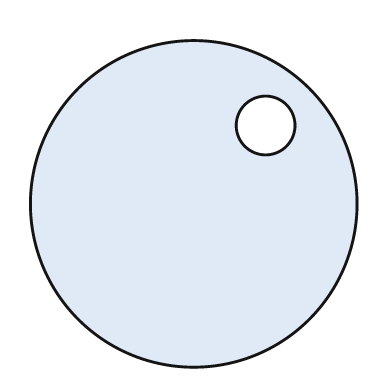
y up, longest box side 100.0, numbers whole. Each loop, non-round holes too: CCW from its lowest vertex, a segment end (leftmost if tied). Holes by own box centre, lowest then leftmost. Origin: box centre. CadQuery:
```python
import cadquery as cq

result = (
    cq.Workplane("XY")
    .moveTo(0.0, 0.0)
    .circle(50.0)
    .moveTo(22.0, 24.0)
    .circle(9.0)
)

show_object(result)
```